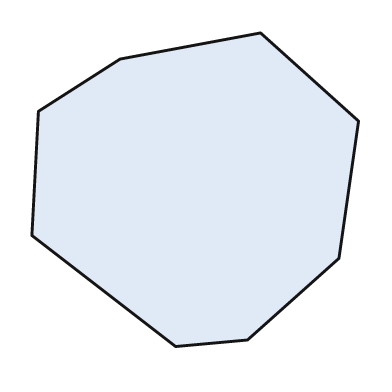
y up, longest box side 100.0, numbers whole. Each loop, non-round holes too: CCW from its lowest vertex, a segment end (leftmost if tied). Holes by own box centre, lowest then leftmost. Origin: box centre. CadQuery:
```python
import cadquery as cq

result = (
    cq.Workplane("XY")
    .moveTo(-6.0, -48.0)
    .lineTo(16.0, -46.0)
    .lineTo(44.0, -21.0)
    .lineTo(50.0, 21.0)
    .lineTo(20.0, 48.0)
    .lineTo(-23.0, 40.0)
    .lineTo(-48.0, 24.0)
    .lineTo(-50.0, -14.0)
    .close()
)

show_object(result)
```